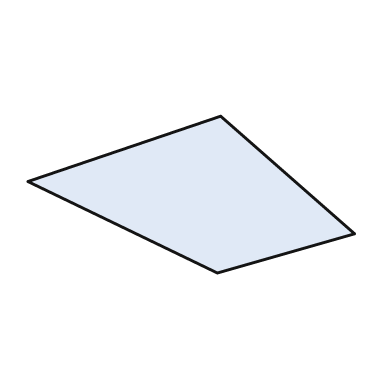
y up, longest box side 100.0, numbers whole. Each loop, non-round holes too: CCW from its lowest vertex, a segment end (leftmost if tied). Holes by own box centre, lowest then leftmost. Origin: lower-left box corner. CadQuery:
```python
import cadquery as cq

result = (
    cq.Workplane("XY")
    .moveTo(58.0, 0.0)
    .lineTo(100.0, 12.0)
    .lineTo(59.0, 48.0)
    .lineTo(0.0, 28.0)
    .close()
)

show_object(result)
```